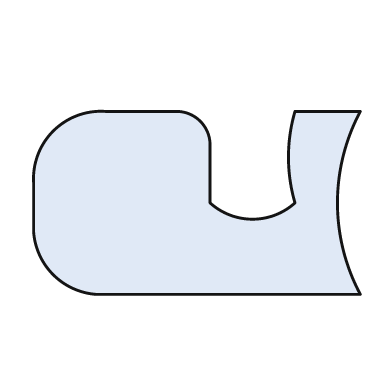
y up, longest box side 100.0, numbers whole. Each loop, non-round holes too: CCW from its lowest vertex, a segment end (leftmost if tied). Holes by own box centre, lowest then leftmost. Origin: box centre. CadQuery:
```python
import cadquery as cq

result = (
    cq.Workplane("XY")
    .moveTo(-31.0, -28.0)
    .lineTo(50.0, -28.0)
    .threePointArc((43.0, 0.0), (50.0, 28.0))
    .lineTo(30.0, 28.0)
    .threePointArc((28.0, 14.0), (30.0, 0.0))
    .threePointArc((17.0, -5.0), (4.0, 0.0))
    .lineTo(4.0, 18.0)
    .threePointArc((1.0, 25.0), (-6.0, 28.0))
    .lineTo(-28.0, 28.0)
    .threePointArc((-44.0, 22.0), (-50.0, 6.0))
    .lineTo(-50.0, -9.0)
    .threePointArc((-44.0, -22.0), (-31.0, -28.0))
    .close()
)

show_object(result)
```